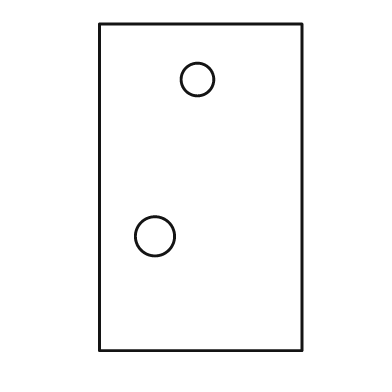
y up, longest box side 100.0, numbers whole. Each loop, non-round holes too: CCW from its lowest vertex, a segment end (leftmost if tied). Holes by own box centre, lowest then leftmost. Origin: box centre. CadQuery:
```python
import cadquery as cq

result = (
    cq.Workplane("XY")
    .moveTo(-31.0, -50.0)
    .lineTo(31.0, -50.0)
    .lineTo(31.0, 50.0)
    .lineTo(-31.0, 50.0)
    .close()
    .moveTo(-14.0, -15.0)
    .circle(6.0)
    .moveTo(-1.0, 33.0)
    .circle(5.0)
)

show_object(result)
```